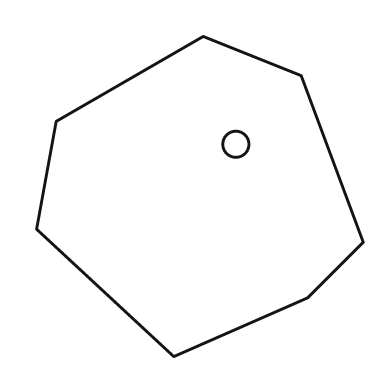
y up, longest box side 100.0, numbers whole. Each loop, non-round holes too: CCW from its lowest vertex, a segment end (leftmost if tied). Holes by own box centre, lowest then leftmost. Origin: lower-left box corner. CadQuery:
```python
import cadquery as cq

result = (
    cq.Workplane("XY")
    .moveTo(42.0, 0.0)
    .lineTo(83.0, 18.0)
    .lineTo(100.0, 35.0)
    .lineTo(81.0, 86.0)
    .lineTo(51.0, 98.0)
    .lineTo(6.0, 72.0)
    .lineTo(0.0, 39.0)
    .close()
    .moveTo(61.0, 65.0)
    .circle(4.0)
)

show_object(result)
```